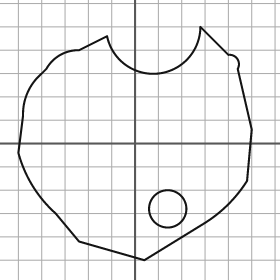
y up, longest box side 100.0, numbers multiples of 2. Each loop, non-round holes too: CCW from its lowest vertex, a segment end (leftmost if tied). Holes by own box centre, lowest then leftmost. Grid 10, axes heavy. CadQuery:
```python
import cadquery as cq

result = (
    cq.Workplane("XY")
    .moveTo(4.0, -50.0)
    .lineTo(30.0, -34.0)
    .threePointArc((40.0, -26.0), (48.0, -16.0))
    .lineTo(50.0, 6.0)
    .lineTo(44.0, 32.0)
    .threePointArc((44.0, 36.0), (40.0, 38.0))
    .lineTo(28.0, 50.0)
    .threePointArc((10.0, 30.0), (-12.0, 46.0))
    .lineTo(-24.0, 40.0)
    .threePointArc((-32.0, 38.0), (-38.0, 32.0))
    .lineTo(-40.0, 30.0)
    .threePointArc((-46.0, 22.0), (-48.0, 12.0))
    .lineTo(-50.0, -4.0)
    .threePointArc((-44.0, -18.0), (-34.0, -30.0))
    .lineTo(-24.0, -42.0)
    .close()
    .moveTo(14.0, -28.0)
    .circle(8.0)
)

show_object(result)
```